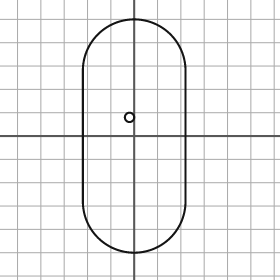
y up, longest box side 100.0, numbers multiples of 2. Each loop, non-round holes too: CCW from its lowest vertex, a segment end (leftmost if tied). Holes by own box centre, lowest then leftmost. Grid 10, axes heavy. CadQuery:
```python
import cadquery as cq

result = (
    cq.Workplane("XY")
    .moveTo(-22.0, -28.0)
    .threePointArc((0.0, -50.0), (22.0, -28.0))
    .lineTo(22.0, 28.0)
    .threePointArc((0.0, 50.0), (-22.0, 28.0))
    .close()
    .moveTo(-2.0, 8.0)
    .circle(2.0)
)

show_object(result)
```